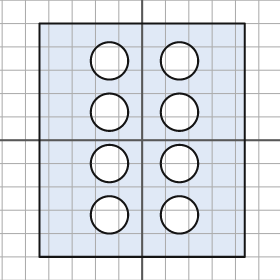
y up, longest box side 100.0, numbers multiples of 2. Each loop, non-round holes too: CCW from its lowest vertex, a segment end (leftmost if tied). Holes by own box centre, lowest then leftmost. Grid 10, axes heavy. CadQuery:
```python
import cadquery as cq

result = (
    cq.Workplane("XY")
    .moveTo(-44.0, -50.0)
    .lineTo(44.0, -50.0)
    .lineTo(44.0, 50.0)
    .lineTo(-44.0, 50.0)
    .close()
    .moveTo(-14.0, -32.0)
    .circle(8.0)
    .moveTo(16.0, -32.0)
    .circle(8.0)
    .moveTo(-14.0, -10.0)
    .circle(8.0)
    .moveTo(16.0, -10.0)
    .circle(8.0)
    .moveTo(-14.0, 12.0)
    .circle(8.0)
    .moveTo(16.0, 12.0)
    .circle(8.0)
    .moveTo(-14.0, 34.0)
    .circle(8.0)
    .moveTo(16.0, 34.0)
    .circle(8.0)
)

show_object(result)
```